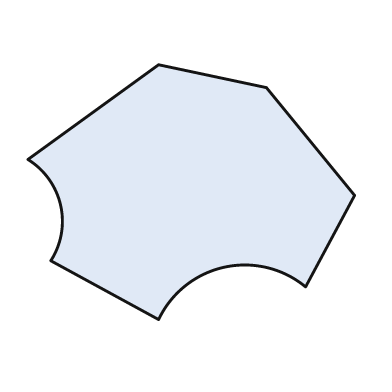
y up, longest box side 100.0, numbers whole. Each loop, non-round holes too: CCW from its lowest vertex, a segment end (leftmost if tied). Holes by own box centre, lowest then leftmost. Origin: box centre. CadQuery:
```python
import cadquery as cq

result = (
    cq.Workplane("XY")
    .moveTo(-10.0, -39.0)
    .threePointArc((10.0, -23.0), (35.0, -29.0))
    .lineTo(50.0, -1.0)
    .lineTo(23.0, 32.0)
    .lineTo(-10.0, 39.0)
    .lineTo(-50.0, 10.0)
    .threePointArc((-40.0, -4.0), (-43.0, -21.0))
    .close()
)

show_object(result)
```